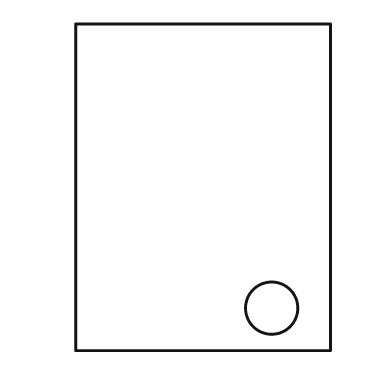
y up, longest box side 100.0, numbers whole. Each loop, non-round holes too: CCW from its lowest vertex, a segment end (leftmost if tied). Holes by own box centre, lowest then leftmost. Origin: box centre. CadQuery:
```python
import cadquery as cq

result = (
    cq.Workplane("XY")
    .moveTo(-39.0, -50.0)
    .lineTo(39.0, -50.0)
    .lineTo(39.0, 50.0)
    .lineTo(-39.0, 50.0)
    .close()
    .moveTo(21.0, -37.0)
    .circle(8.0)
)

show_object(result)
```